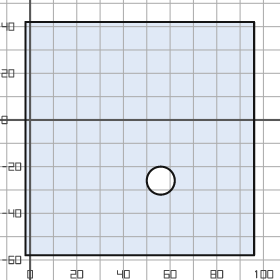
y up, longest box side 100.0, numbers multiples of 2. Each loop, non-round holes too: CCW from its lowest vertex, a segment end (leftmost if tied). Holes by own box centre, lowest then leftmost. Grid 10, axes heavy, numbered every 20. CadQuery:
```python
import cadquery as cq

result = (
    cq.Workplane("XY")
    .moveTo(-2.0, -58.0)
    .lineTo(96.0, -58.0)
    .lineTo(96.0, 42.0)
    .lineTo(-2.0, 42.0)
    .close()
    .moveTo(56.0, -26.0)
    .circle(6.0)
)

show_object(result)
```